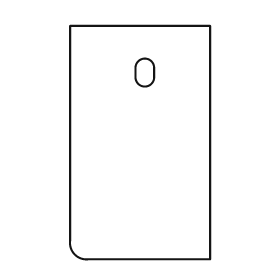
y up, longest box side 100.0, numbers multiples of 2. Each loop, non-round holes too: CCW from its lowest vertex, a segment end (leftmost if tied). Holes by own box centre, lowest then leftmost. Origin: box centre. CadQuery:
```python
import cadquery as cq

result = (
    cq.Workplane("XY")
    .moveTo(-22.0, -50.0)
    .lineTo(30.0, -50.0)
    .lineTo(30.0, 50.0)
    .lineTo(-30.0, 50.0)
    .lineTo(-30.0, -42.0)
    .threePointArc((-28.0, -48.0), (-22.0, -50.0))
    .close()
    .moveTo(-2.0, 28.0)
    .threePointArc((2.0, 24.0), (6.0, 28.0))
    .lineTo(6.0, 32.0)
    .threePointArc((2.0, 36.0), (-2.0, 32.0))
    .close()
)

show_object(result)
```